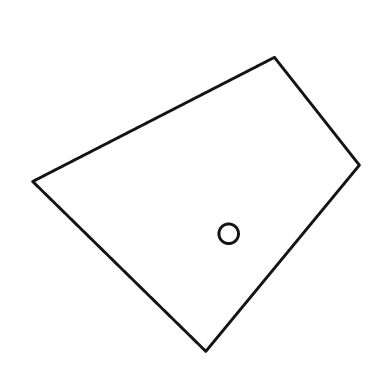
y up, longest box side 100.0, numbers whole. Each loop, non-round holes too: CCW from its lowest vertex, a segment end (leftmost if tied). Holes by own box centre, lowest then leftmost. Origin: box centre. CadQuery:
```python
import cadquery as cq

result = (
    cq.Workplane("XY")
    .moveTo(3.0, -45.0)
    .lineTo(50.0, 12.0)
    .lineTo(24.0, 45.0)
    .lineTo(-50.0, 7.0)
    .close()
    .moveTo(10.0, -9.0)
    .circle(3.0)
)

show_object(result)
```